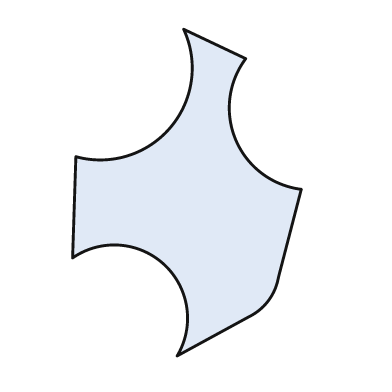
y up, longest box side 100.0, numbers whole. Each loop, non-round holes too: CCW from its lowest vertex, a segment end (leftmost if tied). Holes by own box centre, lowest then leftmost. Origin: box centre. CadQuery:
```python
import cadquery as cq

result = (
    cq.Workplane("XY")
    .moveTo(-3.0, -50.0)
    .lineTo(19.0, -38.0)
    .threePointArc((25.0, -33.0), (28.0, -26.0))
    .lineTo(35.0, 1.0)
    .threePointArc((15.0, 16.0), (18.0, 41.0))
    .lineTo(-1.0, 50.0)
    .threePointArc((-5.0, 20.0), (-34.0, 11.0))
    .lineTo(-35.0, -20.0)
    .threePointArc((-7.0, -22.0), (-3.0, -50.0))
    .close()
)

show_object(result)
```